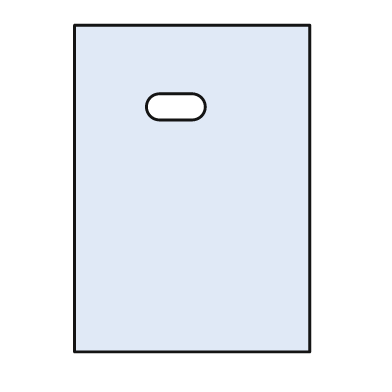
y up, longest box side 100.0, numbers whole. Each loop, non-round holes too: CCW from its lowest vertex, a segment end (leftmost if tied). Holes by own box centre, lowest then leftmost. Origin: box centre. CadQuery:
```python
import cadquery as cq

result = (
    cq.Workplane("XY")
    .moveTo(-36.0, -50.0)
    .lineTo(36.0, -50.0)
    .lineTo(36.0, 50.0)
    .lineTo(-36.0, 50.0)
    .close()
    .moveTo(-10.0, 21.0)
    .lineTo(0.0, 21.0)
    .threePointArc((4.0, 25.0), (0.0, 29.0))
    .lineTo(-10.0, 29.0)
    .threePointArc((-14.0, 25.0), (-10.0, 21.0))
    .close()
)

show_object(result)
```